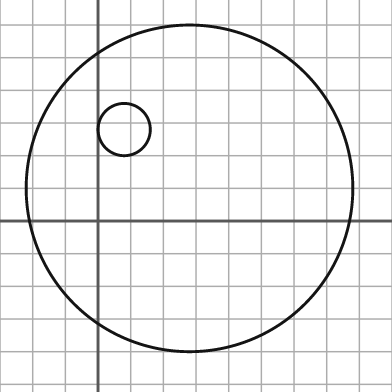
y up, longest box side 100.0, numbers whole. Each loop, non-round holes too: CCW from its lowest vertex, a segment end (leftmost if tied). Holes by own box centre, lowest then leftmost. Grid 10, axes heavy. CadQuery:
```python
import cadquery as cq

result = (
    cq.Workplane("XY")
    .moveTo(28.0, 10.0)
    .circle(50.0)
    .moveTo(8.0, 28.0)
    .circle(8.0)
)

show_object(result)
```